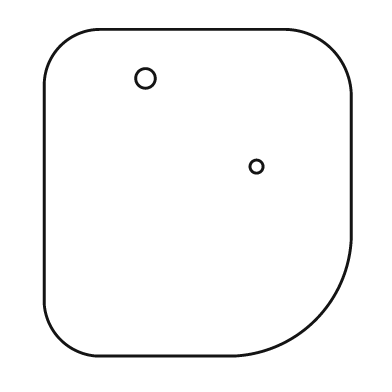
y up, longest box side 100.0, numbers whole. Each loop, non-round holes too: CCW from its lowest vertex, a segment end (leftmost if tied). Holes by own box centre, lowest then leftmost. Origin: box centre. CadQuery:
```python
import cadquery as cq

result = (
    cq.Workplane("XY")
    .moveTo(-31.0, -50.0)
    .lineTo(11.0, -50.0)
    .threePointArc((36.0, -39.0), (47.0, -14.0))
    .lineTo(47.0, 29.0)
    .threePointArc((41.0, 44.0), (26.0, 50.0))
    .lineTo(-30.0, 50.0)
    .threePointArc((-42.0, 45.0), (-47.0, 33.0))
    .lineTo(-47.0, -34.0)
    .threePointArc((-42.0, -45.0), (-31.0, -50.0))
    .close()
    .moveTo(18.0, 8.0)
    .circle(2.0)
    .moveTo(-16.0, 35.0)
    .circle(3.0)
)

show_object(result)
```